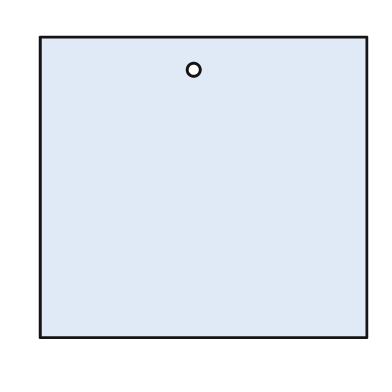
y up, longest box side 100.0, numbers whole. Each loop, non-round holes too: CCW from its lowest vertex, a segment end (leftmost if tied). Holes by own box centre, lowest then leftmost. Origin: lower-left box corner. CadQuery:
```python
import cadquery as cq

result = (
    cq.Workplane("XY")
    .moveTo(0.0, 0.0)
    .lineTo(100.0, 0.0)
    .lineTo(100.0, 92.0)
    .lineTo(0.0, 92.0)
    .close()
    .moveTo(47.0, 82.0)
    .circle(2.0)
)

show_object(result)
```